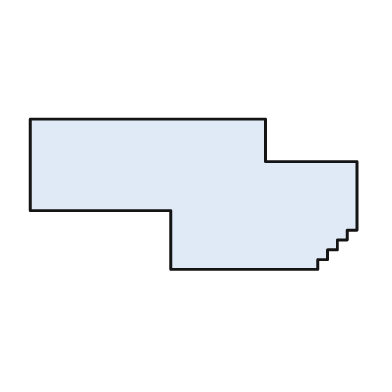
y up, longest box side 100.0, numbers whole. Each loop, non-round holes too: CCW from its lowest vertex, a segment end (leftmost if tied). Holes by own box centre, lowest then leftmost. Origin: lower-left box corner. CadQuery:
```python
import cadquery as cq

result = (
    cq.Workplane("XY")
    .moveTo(43.0, 0.0)
    .lineTo(88.0, 0.0)
    .lineTo(88.0, 3.0)
    .lineTo(91.0, 3.0)
    .lineTo(91.0, 6.0)
    .lineTo(94.0, 6.0)
    .lineTo(94.0, 9.0)
    .lineTo(97.0, 9.0)
    .lineTo(97.0, 12.0)
    .lineTo(100.0, 12.0)
    .lineTo(100.0, 33.0)
    .lineTo(72.0, 33.0)
    .lineTo(72.0, 46.0)
    .lineTo(0.0, 46.0)
    .lineTo(0.0, 18.0)
    .lineTo(43.0, 18.0)
    .close()
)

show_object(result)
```